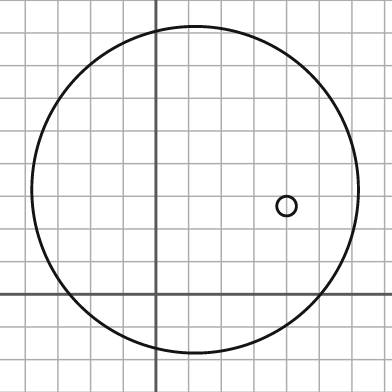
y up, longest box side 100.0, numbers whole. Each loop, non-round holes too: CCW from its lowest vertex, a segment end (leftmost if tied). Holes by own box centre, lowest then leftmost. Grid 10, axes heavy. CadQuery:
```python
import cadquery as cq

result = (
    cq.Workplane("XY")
    .moveTo(12.0, 32.0)
    .circle(50.0)
    .moveTo(40.0, 27.0)
    .circle(3.0)
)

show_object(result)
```